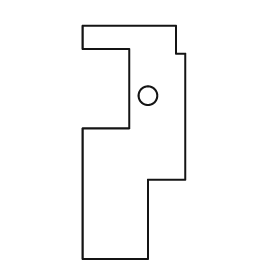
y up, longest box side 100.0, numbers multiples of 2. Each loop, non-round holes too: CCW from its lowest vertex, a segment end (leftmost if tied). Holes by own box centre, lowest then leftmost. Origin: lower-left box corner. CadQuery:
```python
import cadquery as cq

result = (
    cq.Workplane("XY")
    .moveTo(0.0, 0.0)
    .lineTo(28.0, 0.0)
    .lineTo(28.0, 34.0)
    .lineTo(44.0, 34.0)
    .lineTo(44.0, 88.0)
    .lineTo(40.0, 88.0)
    .lineTo(40.0, 100.0)
    .lineTo(0.0, 100.0)
    .lineTo(0.0, 90.0)
    .lineTo(20.0, 90.0)
    .lineTo(20.0, 56.0)
    .lineTo(0.0, 56.0)
    .close()
    .moveTo(28.0, 70.0)
    .circle(4.0)
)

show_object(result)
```